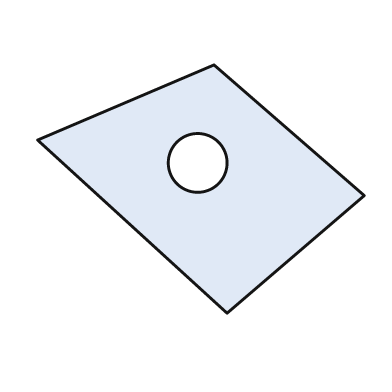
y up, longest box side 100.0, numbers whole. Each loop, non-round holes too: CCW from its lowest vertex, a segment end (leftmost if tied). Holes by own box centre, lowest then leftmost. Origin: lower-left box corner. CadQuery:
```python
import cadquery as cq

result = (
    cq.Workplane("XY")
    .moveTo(58.0, 0.0)
    .lineTo(100.0, 36.0)
    .lineTo(54.0, 76.0)
    .lineTo(0.0, 53.0)
    .close()
    .moveTo(49.0, 46.0)
    .circle(9.0)
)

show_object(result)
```